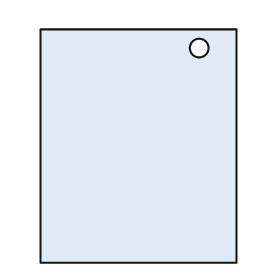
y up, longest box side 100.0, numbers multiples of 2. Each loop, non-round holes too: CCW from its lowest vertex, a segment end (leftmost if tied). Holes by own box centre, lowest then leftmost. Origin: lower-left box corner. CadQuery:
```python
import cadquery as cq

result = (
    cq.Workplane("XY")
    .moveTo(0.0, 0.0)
    .lineTo(84.0, 0.0)
    .lineTo(84.0, 100.0)
    .lineTo(0.0, 100.0)
    .close()
    .moveTo(68.0, 92.0)
    .circle(4.0)
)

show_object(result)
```